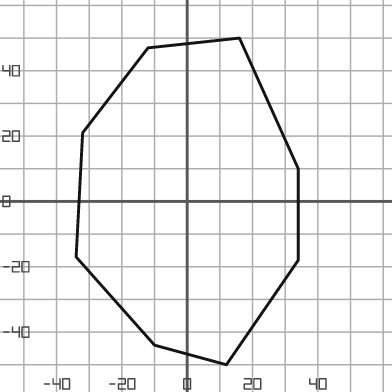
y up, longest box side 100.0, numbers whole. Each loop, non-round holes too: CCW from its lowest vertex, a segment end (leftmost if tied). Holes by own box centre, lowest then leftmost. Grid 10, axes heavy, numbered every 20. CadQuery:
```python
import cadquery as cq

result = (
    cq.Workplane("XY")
    .moveTo(12.0, -50.0)
    .lineTo(34.0, -18.0)
    .lineTo(34.0, 10.0)
    .lineTo(16.0, 50.0)
    .lineTo(-12.0, 47.0)
    .lineTo(-32.0, 21.0)
    .lineTo(-34.0, -17.0)
    .lineTo(-10.0, -44.0)
    .close()
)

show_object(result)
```